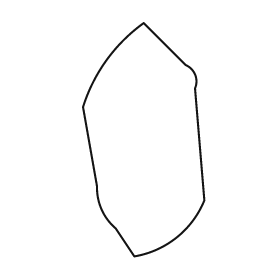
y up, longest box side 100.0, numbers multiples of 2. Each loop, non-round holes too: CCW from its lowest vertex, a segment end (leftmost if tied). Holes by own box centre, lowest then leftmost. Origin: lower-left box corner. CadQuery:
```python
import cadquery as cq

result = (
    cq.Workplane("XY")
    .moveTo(22.0, 0.0)
    .threePointArc((40.0, 8.0), (52.0, 24.0))
    .lineTo(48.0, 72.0)
    .threePointArc((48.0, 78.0), (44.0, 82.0))
    .lineTo(26.0, 100.0)
    .threePointArc((10.0, 84.0), (0.0, 64.0))
    .lineTo(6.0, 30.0)
    .threePointArc((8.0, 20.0), (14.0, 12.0))
    .close()
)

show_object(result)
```